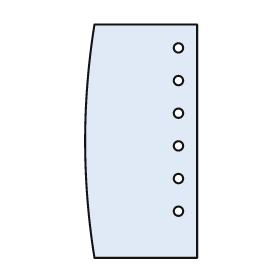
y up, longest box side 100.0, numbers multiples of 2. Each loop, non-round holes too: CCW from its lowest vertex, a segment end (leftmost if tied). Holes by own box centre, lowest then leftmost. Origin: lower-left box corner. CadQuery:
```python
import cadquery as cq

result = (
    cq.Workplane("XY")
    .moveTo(4.0, 0.0)
    .lineTo(48.0, 0.0)
    .lineTo(48.0, 100.0)
    .lineTo(4.0, 100.0)
    .threePointArc((0.0, 50.0), (4.0, 0.0))
    .close()
    .moveTo(40.0, 20.0)
    .circle(2.0)
    .moveTo(40.0, 34.0)
    .circle(2.0)
    .moveTo(40.0, 48.0)
    .circle(2.0)
    .moveTo(40.0, 62.0)
    .circle(2.0)
    .moveTo(40.0, 76.0)
    .circle(2.0)
    .moveTo(40.0, 90.0)
    .circle(2.0)
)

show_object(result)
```